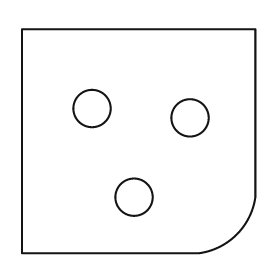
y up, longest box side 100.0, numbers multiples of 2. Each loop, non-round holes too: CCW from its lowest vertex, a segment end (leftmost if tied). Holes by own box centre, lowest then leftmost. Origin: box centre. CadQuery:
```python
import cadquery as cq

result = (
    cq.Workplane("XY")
    .moveTo(-50.0, -48.0)
    .lineTo(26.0, -48.0)
    .threePointArc((42.0, -40.0), (50.0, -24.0))
    .lineTo(50.0, 48.0)
    .lineTo(-50.0, 48.0)
    .close()
    .moveTo(-2.0, -24.0)
    .circle(8.0)
    .moveTo(22.0, 10.0)
    .circle(8.0)
    .moveTo(-20.0, 14.0)
    .circle(8.0)
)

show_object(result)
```